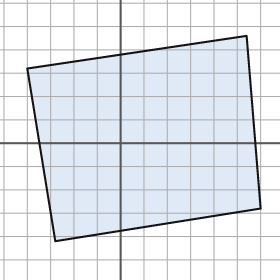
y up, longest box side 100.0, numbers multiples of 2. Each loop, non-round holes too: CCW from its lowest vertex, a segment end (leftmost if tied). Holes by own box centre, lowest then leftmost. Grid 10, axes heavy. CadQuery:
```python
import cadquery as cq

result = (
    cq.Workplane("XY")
    .moveTo(-28.0, -42.0)
    .lineTo(60.0, -28.0)
    .lineTo(54.0, 46.0)
    .lineTo(-40.0, 32.0)
    .close()
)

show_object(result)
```